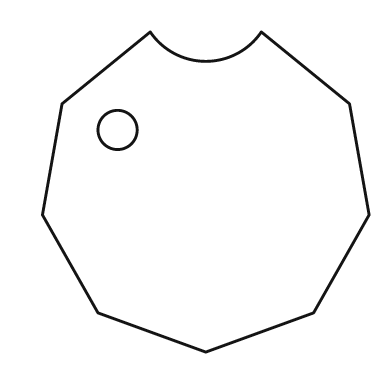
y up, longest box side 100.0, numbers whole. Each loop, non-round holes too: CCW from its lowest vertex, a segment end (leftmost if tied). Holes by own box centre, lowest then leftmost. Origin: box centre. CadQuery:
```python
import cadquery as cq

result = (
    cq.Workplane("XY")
    .moveTo(0.0, -49.0)
    .lineTo(33.0, -37.0)
    .lineTo(50.0, -7.0)
    .lineTo(44.0, 27.0)
    .lineTo(17.0, 49.0)
    .threePointArc((0.0, 40.0), (-17.0, 49.0))
    .lineTo(-44.0, 27.0)
    .lineTo(-50.0, -7.0)
    .lineTo(-33.0, -37.0)
    .close()
    .moveTo(-27.0, 19.0)
    .circle(6.0)
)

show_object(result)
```